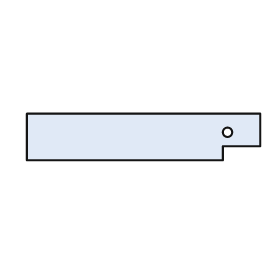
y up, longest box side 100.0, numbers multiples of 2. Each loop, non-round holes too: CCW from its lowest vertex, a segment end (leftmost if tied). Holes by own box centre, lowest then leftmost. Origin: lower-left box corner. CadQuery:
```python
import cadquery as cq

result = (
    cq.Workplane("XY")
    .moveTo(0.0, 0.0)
    .lineTo(84.0, 0.0)
    .lineTo(84.0, 6.0)
    .lineTo(100.0, 6.0)
    .lineTo(100.0, 20.0)
    .lineTo(0.0, 20.0)
    .close()
    .moveTo(86.0, 12.0)
    .circle(2.0)
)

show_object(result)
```